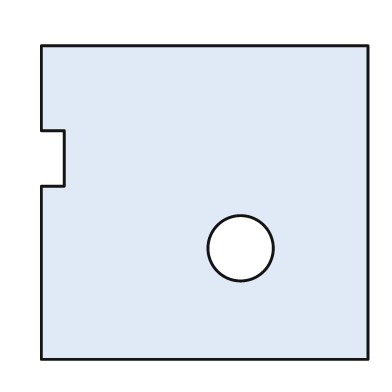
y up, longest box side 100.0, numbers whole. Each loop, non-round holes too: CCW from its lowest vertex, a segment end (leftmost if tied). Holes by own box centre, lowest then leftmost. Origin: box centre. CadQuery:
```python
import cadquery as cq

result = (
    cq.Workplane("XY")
    .moveTo(-50.0, -48.0)
    .lineTo(50.0, -48.0)
    .lineTo(50.0, 48.0)
    .lineTo(-50.0, 48.0)
    .lineTo(-50.0, 22.0)
    .lineTo(-43.0, 22.0)
    .lineTo(-43.0, 5.0)
    .lineTo(-50.0, 5.0)
    .close()
    .moveTo(11.0, -14.0)
    .circle(10.0)
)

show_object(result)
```